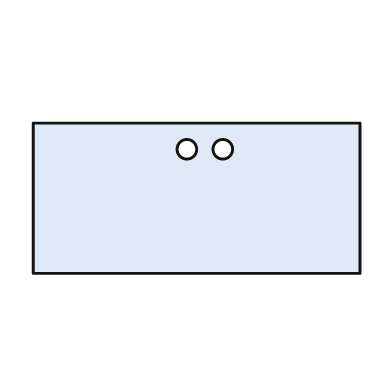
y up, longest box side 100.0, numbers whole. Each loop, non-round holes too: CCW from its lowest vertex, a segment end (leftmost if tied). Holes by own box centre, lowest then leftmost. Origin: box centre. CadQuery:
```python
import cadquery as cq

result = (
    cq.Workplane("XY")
    .moveTo(-50.0, -23.0)
    .lineTo(50.0, -23.0)
    .lineTo(50.0, 23.0)
    .lineTo(-50.0, 23.0)
    .close()
    .moveTo(-3.0, 15.0)
    .circle(3.0)
    .moveTo(8.0, 15.0)
    .circle(3.0)
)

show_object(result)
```